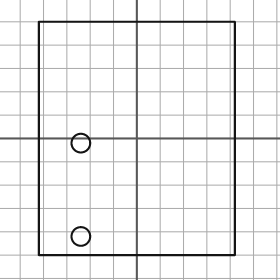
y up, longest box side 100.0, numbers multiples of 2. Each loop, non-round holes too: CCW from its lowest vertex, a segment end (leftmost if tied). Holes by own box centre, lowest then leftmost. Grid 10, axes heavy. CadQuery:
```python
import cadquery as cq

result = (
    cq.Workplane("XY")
    .moveTo(-42.0, -50.0)
    .lineTo(42.0, -50.0)
    .lineTo(42.0, 50.0)
    .lineTo(-42.0, 50.0)
    .close()
    .moveTo(-24.0, -42.0)
    .circle(4.0)
    .moveTo(-24.0, -2.0)
    .circle(4.0)
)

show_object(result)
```